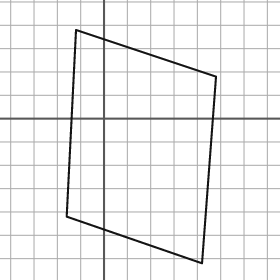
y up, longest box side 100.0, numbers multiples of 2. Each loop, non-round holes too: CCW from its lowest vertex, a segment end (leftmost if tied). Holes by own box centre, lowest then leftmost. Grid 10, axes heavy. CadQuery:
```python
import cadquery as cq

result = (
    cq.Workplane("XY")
    .moveTo(42.0, -62.0)
    .lineTo(48.0, 18.0)
    .lineTo(-12.0, 38.0)
    .lineTo(-16.0, -42.0)
    .close()
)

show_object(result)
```